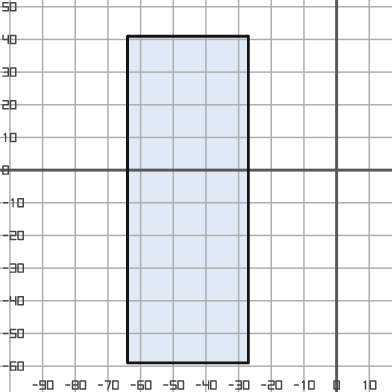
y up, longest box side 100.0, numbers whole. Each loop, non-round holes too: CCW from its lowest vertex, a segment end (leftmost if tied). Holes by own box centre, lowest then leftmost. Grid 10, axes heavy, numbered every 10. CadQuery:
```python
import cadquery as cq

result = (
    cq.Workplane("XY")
    .moveTo(-64.0, -59.0)
    .lineTo(-27.0, -59.0)
    .lineTo(-27.0, 41.0)
    .lineTo(-64.0, 41.0)
    .close()
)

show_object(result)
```